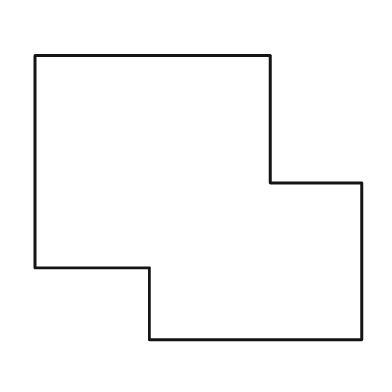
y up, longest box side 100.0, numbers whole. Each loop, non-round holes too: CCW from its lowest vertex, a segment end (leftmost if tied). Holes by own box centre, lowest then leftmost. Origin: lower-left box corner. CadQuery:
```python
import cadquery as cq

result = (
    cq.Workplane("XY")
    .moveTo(35.0, 0.0)
    .lineTo(100.0, 0.0)
    .lineTo(100.0, 48.0)
    .lineTo(72.0, 48.0)
    .lineTo(72.0, 87.0)
    .lineTo(0.0, 87.0)
    .lineTo(0.0, 22.0)
    .lineTo(35.0, 22.0)
    .close()
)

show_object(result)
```